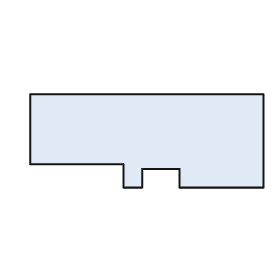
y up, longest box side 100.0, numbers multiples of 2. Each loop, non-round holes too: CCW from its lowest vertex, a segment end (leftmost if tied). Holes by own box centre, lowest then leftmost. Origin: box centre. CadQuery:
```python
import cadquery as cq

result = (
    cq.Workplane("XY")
    .moveTo(-10.0, -20.0)
    .lineTo(-2.0, -20.0)
    .lineTo(-2.0, -12.0)
    .lineTo(14.0, -12.0)
    .lineTo(14.0, -20.0)
    .lineTo(50.0, -20.0)
    .lineTo(50.0, 20.0)
    .lineTo(-50.0, 20.0)
    .lineTo(-50.0, -10.0)
    .lineTo(-10.0, -10.0)
    .close()
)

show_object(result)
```